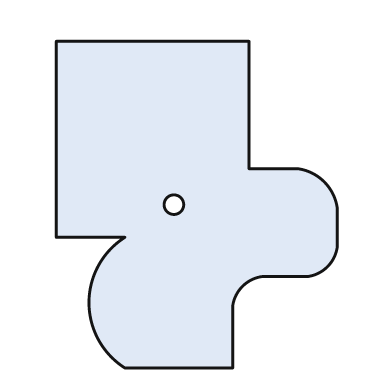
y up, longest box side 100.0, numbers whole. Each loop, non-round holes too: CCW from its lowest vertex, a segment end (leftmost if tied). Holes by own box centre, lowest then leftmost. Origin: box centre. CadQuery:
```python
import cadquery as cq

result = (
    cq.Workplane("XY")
    .moveTo(-22.0, -50.0)
    .lineTo(11.0, -50.0)
    .lineTo(11.0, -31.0)
    .threePointArc((14.0, -25.0), (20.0, -22.0))
    .lineTo(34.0, -22.0)
    .threePointArc((40.0, -19.0), (43.0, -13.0))
    .lineTo(43.0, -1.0)
    .threePointArc((39.0, 7.0), (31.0, 11.0))
    .lineTo(16.0, 11.0)
    .lineTo(16.0, 50.0)
    .lineTo(-43.0, 50.0)
    .lineTo(-43.0, -10.0)
    .lineTo(-22.0, -10.0)
    .threePointArc((-33.0, -30.0), (-22.0, -50.0))
    .close()
    .moveTo(-7.0, 0.0)
    .circle(3.0)
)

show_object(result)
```